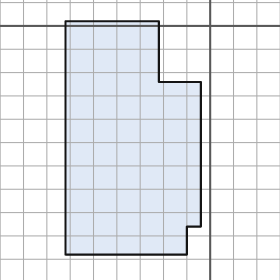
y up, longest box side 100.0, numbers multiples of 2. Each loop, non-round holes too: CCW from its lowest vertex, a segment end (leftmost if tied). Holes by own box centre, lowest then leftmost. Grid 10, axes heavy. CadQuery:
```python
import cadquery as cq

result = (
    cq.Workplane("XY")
    .moveTo(-62.0, -98.0)
    .lineTo(-10.0, -98.0)
    .lineTo(-10.0, -86.0)
    .lineTo(-4.0, -86.0)
    .lineTo(-4.0, -24.0)
    .lineTo(-22.0, -24.0)
    .lineTo(-22.0, 2.0)
    .lineTo(-62.0, 2.0)
    .close()
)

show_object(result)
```